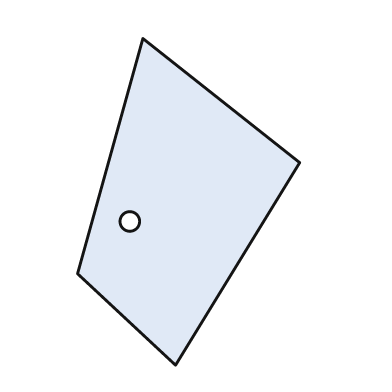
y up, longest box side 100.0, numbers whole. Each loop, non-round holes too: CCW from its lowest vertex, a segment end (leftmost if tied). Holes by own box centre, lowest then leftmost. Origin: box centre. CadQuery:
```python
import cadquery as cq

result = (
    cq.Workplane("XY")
    .moveTo(-4.0, -50.0)
    .lineTo(34.0, 12.0)
    .lineTo(-14.0, 50.0)
    .lineTo(-34.0, -22.0)
    .close()
    .moveTo(-18.0, -6.0)
    .circle(3.0)
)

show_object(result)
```